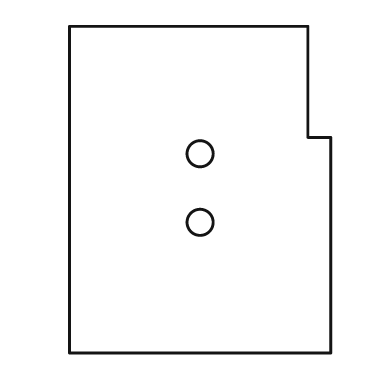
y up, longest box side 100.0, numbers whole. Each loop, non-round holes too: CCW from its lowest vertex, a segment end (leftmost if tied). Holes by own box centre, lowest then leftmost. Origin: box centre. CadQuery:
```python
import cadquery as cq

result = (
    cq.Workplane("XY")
    .moveTo(-40.0, -50.0)
    .lineTo(40.0, -50.0)
    .lineTo(40.0, 16.0)
    .lineTo(33.0, 16.0)
    .lineTo(33.0, 50.0)
    .lineTo(-40.0, 50.0)
    .close()
    .moveTo(0.0, -10.0)
    .circle(4.0)
    .moveTo(0.0, 11.0)
    .circle(4.0)
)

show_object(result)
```